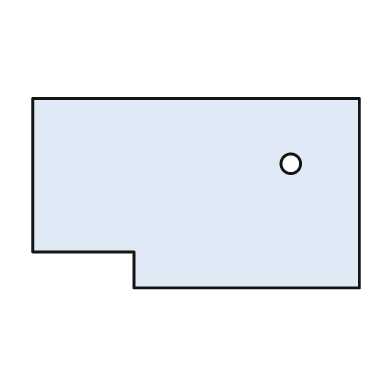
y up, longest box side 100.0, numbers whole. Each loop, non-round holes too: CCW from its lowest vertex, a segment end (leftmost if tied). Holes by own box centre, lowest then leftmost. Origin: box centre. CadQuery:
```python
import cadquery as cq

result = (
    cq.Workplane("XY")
    .moveTo(-19.0, -29.0)
    .lineTo(50.0, -29.0)
    .lineTo(50.0, 29.0)
    .lineTo(-50.0, 29.0)
    .lineTo(-50.0, -18.0)
    .lineTo(-19.0, -18.0)
    .close()
    .moveTo(29.0, 9.0)
    .circle(3.0)
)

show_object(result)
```